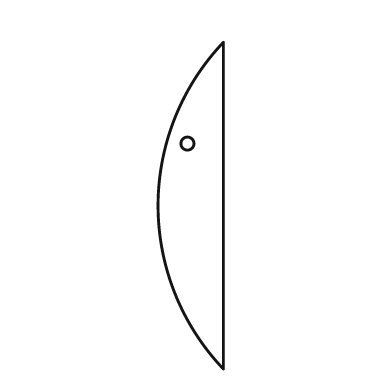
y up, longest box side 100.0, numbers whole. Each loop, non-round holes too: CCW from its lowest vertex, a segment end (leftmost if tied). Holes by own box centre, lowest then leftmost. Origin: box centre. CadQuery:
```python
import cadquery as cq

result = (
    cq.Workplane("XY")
    .moveTo(10.0, -50.0)
    .lineTo(10.0, 50.0)
    .threePointArc((-10.0, 0.0), (10.0, -50.0))
    .close()
    .moveTo(-1.0, 19.0)
    .circle(2.0)
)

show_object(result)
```